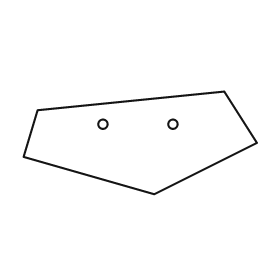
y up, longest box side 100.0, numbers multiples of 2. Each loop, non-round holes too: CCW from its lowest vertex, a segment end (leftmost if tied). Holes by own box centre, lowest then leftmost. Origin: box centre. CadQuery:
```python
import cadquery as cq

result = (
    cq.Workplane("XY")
    .moveTo(6.0, -22.0)
    .lineTo(50.0, 0.0)
    .lineTo(36.0, 22.0)
    .lineTo(-44.0, 14.0)
    .lineTo(-50.0, -6.0)
    .close()
    .moveTo(-16.0, 8.0)
    .circle(2.0)
    .moveTo(14.0, 8.0)
    .circle(2.0)
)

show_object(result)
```